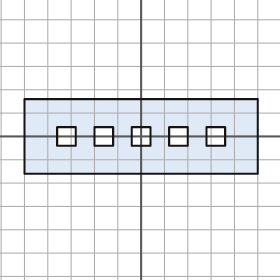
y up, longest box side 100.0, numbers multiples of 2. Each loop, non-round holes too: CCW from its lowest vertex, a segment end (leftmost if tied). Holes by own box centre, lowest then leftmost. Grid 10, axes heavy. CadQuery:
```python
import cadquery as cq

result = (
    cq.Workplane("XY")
    .moveTo(-50.0, -16.0)
    .lineTo(50.0, -16.0)
    .lineTo(50.0, 16.0)
    .lineTo(-50.0, 16.0)
    .close()
    .moveTo(-36.0, -4.0)
    .lineTo(-28.0, -4.0)
    .lineTo(-28.0, 4.0)
    .lineTo(-36.0, 4.0)
    .close()
    .moveTo(-20.0, -4.0)
    .lineTo(-12.0, -4.0)
    .lineTo(-12.0, 4.0)
    .lineTo(-20.0, 4.0)
    .close()
    .moveTo(-4.0, -4.0)
    .lineTo(4.0, -4.0)
    .lineTo(4.0, 4.0)
    .lineTo(-4.0, 4.0)
    .close()
    .moveTo(12.0, -4.0)
    .lineTo(20.0, -4.0)
    .lineTo(20.0, 4.0)
    .lineTo(12.0, 4.0)
    .close()
    .moveTo(28.0, -4.0)
    .lineTo(36.0, -4.0)
    .lineTo(36.0, 4.0)
    .lineTo(28.0, 4.0)
    .close()
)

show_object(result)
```